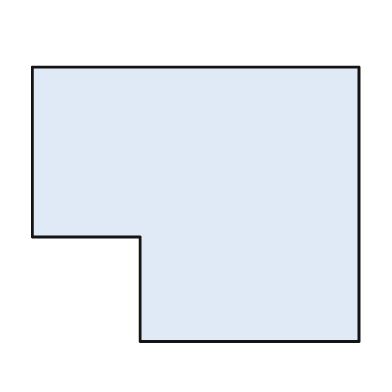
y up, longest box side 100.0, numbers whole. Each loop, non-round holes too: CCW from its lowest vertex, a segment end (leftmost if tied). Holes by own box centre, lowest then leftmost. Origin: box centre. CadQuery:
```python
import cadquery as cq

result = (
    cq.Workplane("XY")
    .moveTo(-17.0, -42.0)
    .lineTo(50.0, -42.0)
    .lineTo(50.0, 42.0)
    .lineTo(-50.0, 42.0)
    .lineTo(-50.0, -10.0)
    .lineTo(-17.0, -10.0)
    .close()
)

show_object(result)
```